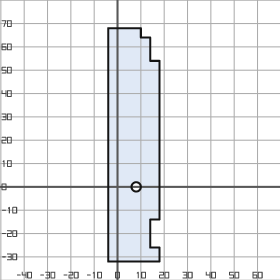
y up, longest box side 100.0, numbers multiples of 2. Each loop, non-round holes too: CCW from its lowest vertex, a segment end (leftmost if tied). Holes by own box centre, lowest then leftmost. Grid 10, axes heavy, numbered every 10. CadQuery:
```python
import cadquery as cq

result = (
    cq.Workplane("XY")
    .moveTo(-4.0, -32.0)
    .lineTo(18.0, -32.0)
    .lineTo(18.0, -26.0)
    .lineTo(14.0, -26.0)
    .lineTo(14.0, -14.0)
    .lineTo(18.0, -14.0)
    .lineTo(18.0, 54.0)
    .lineTo(14.0, 54.0)
    .lineTo(14.0, 64.0)
    .lineTo(10.0, 64.0)
    .lineTo(10.0, 68.0)
    .lineTo(-4.0, 68.0)
    .close()
    .moveTo(8.0, 0.0)
    .circle(2.0)
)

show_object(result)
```